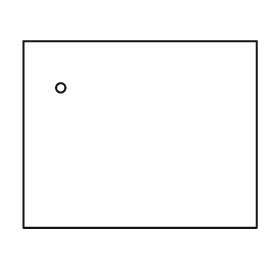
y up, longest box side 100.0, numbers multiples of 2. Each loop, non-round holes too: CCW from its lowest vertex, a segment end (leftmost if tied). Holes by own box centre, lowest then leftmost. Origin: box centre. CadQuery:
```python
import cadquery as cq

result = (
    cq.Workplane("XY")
    .moveTo(-50.0, -40.0)
    .lineTo(50.0, -40.0)
    .lineTo(50.0, 40.0)
    .lineTo(-50.0, 40.0)
    .close()
    .moveTo(-34.0, 20.0)
    .circle(2.0)
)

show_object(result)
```